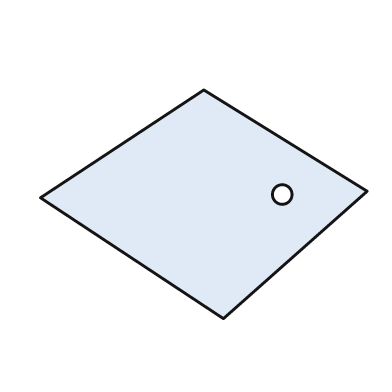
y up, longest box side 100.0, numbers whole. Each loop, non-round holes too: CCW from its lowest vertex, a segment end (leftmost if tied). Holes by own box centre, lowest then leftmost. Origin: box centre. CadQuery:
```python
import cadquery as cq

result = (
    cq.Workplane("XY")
    .moveTo(6.0, -35.0)
    .lineTo(50.0, 4.0)
    .lineTo(0.0, 35.0)
    .lineTo(-50.0, 2.0)
    .close()
    .moveTo(24.0, 3.0)
    .circle(3.0)
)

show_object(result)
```